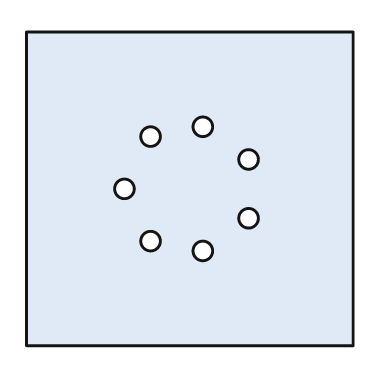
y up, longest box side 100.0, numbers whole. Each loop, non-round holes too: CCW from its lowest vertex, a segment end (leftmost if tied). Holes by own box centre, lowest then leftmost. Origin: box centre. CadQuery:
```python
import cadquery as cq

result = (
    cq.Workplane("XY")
    .moveTo(-50.0, -48.0)
    .lineTo(50.0, -48.0)
    .lineTo(50.0, 48.0)
    .lineTo(-50.0, 48.0)
    .close()
    .moveTo(4.0, -19.0)
    .circle(3.0)
    .moveTo(-12.0, -16.0)
    .circle(3.0)
    .moveTo(18.0, -9.0)
    .circle(3.0)
    .moveTo(-20.0, 0.0)
    .circle(3.0)
    .moveTo(18.0, 9.0)
    .circle(3.0)
    .moveTo(-12.0, 16.0)
    .circle(3.0)
    .moveTo(4.0, 19.0)
    .circle(3.0)
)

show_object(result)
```